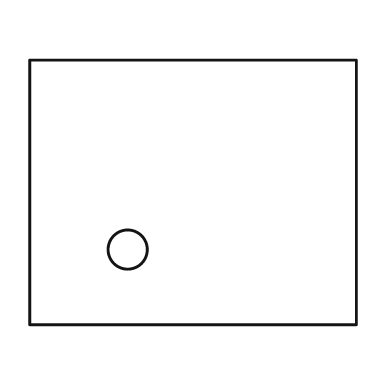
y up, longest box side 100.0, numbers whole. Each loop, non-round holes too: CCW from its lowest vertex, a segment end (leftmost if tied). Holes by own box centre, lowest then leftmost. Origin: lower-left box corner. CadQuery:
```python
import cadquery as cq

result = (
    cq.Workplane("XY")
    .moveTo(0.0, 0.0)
    .lineTo(100.0, 0.0)
    .lineTo(100.0, 81.0)
    .lineTo(0.0, 81.0)
    .close()
    .moveTo(30.0, 23.0)
    .circle(6.0)
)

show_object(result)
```